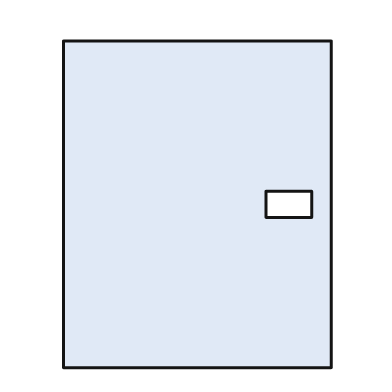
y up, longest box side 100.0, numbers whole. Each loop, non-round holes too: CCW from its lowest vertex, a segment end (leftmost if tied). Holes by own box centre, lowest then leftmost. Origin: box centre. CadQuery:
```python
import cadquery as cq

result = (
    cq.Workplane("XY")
    .moveTo(-41.0, -50.0)
    .lineTo(41.0, -50.0)
    .lineTo(41.0, 50.0)
    .lineTo(-41.0, 50.0)
    .close()
    .moveTo(21.0, -4.0)
    .lineTo(35.0, -4.0)
    .lineTo(35.0, 4.0)
    .lineTo(21.0, 4.0)
    .close()
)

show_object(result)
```